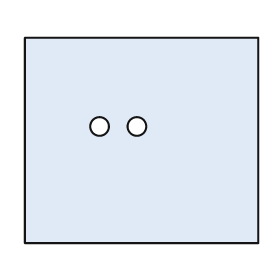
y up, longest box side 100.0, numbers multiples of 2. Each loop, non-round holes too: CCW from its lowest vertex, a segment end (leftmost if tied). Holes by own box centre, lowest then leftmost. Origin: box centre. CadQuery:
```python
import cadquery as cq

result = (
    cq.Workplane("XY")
    .moveTo(-50.0, -44.0)
    .lineTo(50.0, -44.0)
    .lineTo(50.0, 44.0)
    .lineTo(-50.0, 44.0)
    .close()
    .moveTo(-18.0, 6.0)
    .circle(4.0)
    .moveTo(-2.0, 6.0)
    .circle(4.0)
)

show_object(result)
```